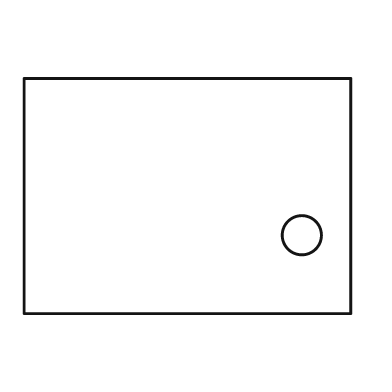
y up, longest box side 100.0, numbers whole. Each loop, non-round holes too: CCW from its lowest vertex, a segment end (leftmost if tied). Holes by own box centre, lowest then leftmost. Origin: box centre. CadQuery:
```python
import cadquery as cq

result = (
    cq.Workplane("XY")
    .moveTo(-50.0, -36.0)
    .lineTo(50.0, -36.0)
    .lineTo(50.0, 36.0)
    .lineTo(-50.0, 36.0)
    .close()
    .moveTo(35.0, -12.0)
    .circle(6.0)
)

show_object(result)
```